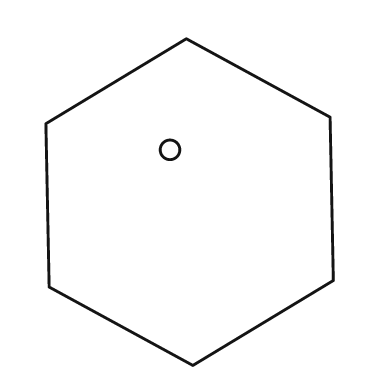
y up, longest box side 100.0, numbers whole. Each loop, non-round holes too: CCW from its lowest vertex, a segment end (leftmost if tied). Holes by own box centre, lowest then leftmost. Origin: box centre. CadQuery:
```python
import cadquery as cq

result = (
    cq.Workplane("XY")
    .moveTo(1.0, -50.0)
    .lineTo(44.0, -24.0)
    .lineTo(43.0, 26.0)
    .lineTo(-1.0, 50.0)
    .lineTo(-44.0, 24.0)
    .lineTo(-43.0, -26.0)
    .close()
    .moveTo(-6.0, 16.0)
    .circle(3.0)
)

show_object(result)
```